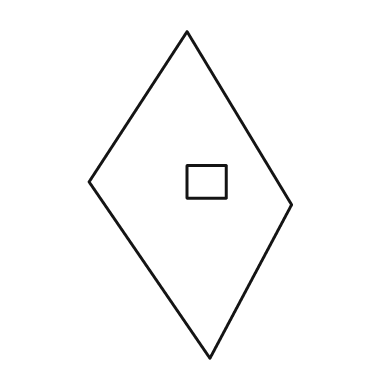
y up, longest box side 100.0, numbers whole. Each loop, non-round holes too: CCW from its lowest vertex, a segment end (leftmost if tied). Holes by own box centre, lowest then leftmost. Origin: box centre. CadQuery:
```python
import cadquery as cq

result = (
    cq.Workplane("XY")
    .moveTo(6.0, -50.0)
    .lineTo(31.0, -3.0)
    .lineTo(-1.0, 50.0)
    .lineTo(-31.0, 4.0)
    .close()
    .moveTo(-1.0, -1.0)
    .lineTo(11.0, -1.0)
    .lineTo(11.0, 9.0)
    .lineTo(-1.0, 9.0)
    .close()
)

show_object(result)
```